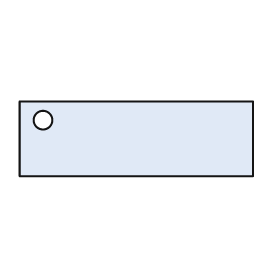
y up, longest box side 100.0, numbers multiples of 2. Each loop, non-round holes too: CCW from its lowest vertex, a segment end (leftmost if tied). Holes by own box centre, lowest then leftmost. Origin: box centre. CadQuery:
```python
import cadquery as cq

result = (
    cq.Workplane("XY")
    .moveTo(-50.0, -16.0)
    .lineTo(50.0, -16.0)
    .lineTo(50.0, 16.0)
    .lineTo(-50.0, 16.0)
    .close()
    .moveTo(-40.0, 8.0)
    .circle(4.0)
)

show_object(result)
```